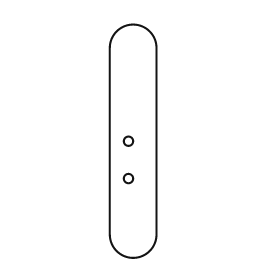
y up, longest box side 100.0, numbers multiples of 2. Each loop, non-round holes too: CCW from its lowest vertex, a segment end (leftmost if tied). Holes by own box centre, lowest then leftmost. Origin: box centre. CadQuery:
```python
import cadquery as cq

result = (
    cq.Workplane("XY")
    .moveTo(-10.0, -40.0)
    .threePointArc((0.0, -50.0), (10.0, -40.0))
    .lineTo(10.0, 40.0)
    .threePointArc((0.0, 50.0), (-10.0, 40.0))
    .close()
    .moveTo(-2.0, -16.0)
    .circle(2.0)
    .moveTo(-2.0, 0.0)
    .circle(2.0)
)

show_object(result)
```